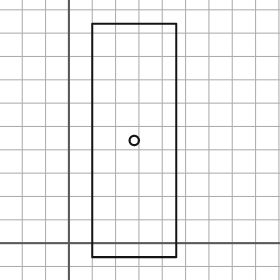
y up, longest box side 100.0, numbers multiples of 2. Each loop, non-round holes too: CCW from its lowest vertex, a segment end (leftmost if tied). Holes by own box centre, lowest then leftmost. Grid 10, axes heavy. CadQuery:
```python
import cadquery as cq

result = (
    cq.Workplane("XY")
    .moveTo(10.0, -6.0)
    .lineTo(46.0, -6.0)
    .lineTo(46.0, 94.0)
    .lineTo(10.0, 94.0)
    .close()
    .moveTo(28.0, 44.0)
    .circle(2.0)
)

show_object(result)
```